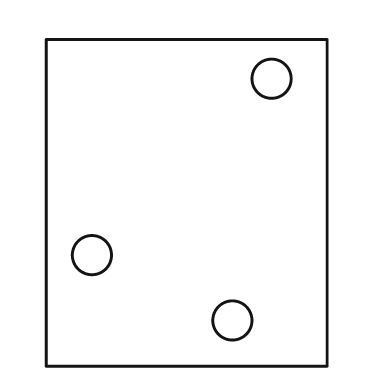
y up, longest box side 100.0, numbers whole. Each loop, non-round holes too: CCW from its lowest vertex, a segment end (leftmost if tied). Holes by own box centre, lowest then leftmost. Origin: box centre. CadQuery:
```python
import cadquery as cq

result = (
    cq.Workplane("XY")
    .moveTo(-43.0, -50.0)
    .lineTo(43.0, -50.0)
    .lineTo(43.0, 50.0)
    .lineTo(-43.0, 50.0)
    .close()
    .moveTo(14.0, -36.0)
    .circle(6.0)
    .moveTo(-29.0, -16.0)
    .circle(6.0)
    .moveTo(26.0, 38.0)
    .circle(6.0)
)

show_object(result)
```